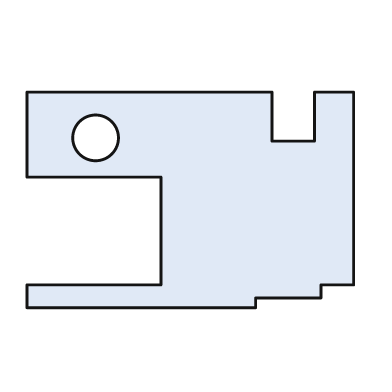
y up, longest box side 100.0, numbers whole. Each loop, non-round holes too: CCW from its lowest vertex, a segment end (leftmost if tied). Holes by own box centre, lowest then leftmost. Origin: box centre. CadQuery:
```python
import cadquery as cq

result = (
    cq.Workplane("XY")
    .moveTo(-50.0, -33.0)
    .lineTo(20.0, -33.0)
    .lineTo(20.0, -30.0)
    .lineTo(40.0, -30.0)
    .lineTo(40.0, -26.0)
    .lineTo(50.0, -26.0)
    .lineTo(50.0, 33.0)
    .lineTo(38.0, 33.0)
    .lineTo(38.0, 18.0)
    .lineTo(25.0, 18.0)
    .lineTo(25.0, 33.0)
    .lineTo(-50.0, 33.0)
    .lineTo(-50.0, 7.0)
    .lineTo(-9.0, 7.0)
    .lineTo(-9.0, -26.0)
    .lineTo(-50.0, -26.0)
    .close()
    .moveTo(-29.0, 19.0)
    .circle(7.0)
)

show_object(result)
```